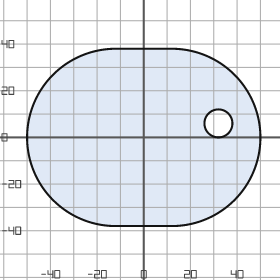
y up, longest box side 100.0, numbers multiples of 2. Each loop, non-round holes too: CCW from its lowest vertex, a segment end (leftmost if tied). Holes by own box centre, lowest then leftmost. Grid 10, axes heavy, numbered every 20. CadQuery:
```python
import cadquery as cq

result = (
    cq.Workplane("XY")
    .moveTo(-12.0, -38.0)
    .lineTo(12.0, -38.0)
    .threePointArc((50.0, 0.0), (12.0, 38.0))
    .lineTo(-12.0, 38.0)
    .threePointArc((-50.0, 0.0), (-12.0, -38.0))
    .close()
    .moveTo(32.0, 6.0)
    .circle(6.0)
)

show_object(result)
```